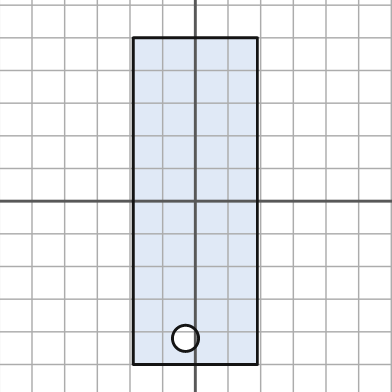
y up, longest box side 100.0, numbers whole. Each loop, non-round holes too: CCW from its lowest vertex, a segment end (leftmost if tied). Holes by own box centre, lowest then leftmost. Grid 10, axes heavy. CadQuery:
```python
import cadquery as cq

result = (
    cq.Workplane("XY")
    .moveTo(-19.0, -50.0)
    .lineTo(19.0, -50.0)
    .lineTo(19.0, 50.0)
    .lineTo(-19.0, 50.0)
    .close()
    .moveTo(-3.0, -42.0)
    .circle(4.0)
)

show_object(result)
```